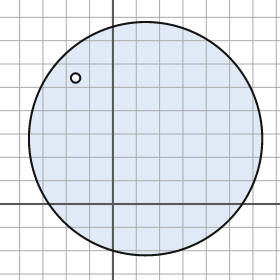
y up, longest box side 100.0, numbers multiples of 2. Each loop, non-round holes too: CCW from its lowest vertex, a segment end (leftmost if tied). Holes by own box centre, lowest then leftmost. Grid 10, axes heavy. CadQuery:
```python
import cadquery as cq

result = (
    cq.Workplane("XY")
    .moveTo(14.0, 28.0)
    .circle(50.0)
    .moveTo(-16.0, 54.0)
    .circle(2.0)
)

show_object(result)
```